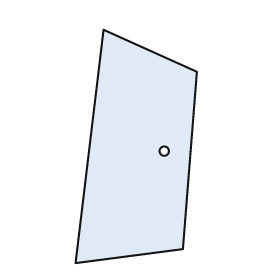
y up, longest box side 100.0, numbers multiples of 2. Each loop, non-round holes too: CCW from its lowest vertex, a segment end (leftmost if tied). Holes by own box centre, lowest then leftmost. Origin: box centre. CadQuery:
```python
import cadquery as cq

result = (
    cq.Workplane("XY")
    .moveTo(-26.0, -50.0)
    .lineTo(20.0, -44.0)
    .lineTo(26.0, 32.0)
    .lineTo(-14.0, 50.0)
    .close()
    .moveTo(12.0, -2.0)
    .circle(2.0)
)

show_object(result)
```